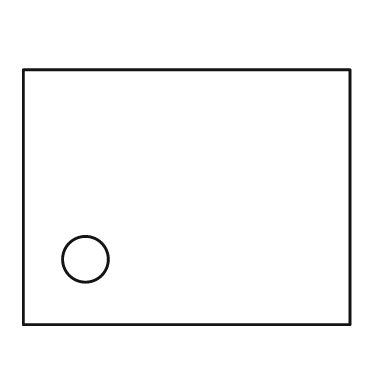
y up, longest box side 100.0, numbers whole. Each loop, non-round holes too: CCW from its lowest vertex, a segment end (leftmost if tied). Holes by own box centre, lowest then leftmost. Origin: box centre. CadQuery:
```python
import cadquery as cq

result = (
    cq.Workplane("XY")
    .moveTo(-50.0, -39.0)
    .lineTo(50.0, -39.0)
    .lineTo(50.0, 39.0)
    .lineTo(-50.0, 39.0)
    .close()
    .moveTo(-31.0, -19.0)
    .circle(7.0)
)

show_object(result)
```